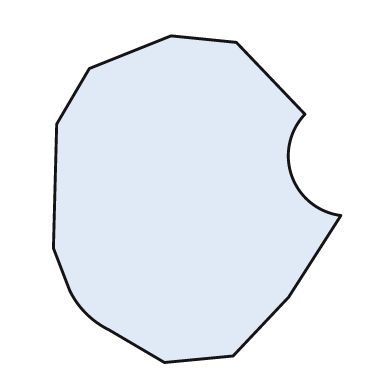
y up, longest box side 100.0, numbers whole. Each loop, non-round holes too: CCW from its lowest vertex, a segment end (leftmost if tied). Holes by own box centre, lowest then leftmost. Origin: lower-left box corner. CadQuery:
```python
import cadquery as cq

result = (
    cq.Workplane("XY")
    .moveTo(34.0, 0.0)
    .lineTo(55.0, 2.0)
    .lineTo(72.0, 20.0)
    .lineTo(88.0, 45.0)
    .threePointArc((73.0, 57.0), (77.0, 76.0))
    .lineTo(56.0, 98.0)
    .lineTo(36.0, 100.0)
    .lineTo(11.0, 90.0)
    .lineTo(1.0, 73.0)
    .lineTo(0.0, 35.0)
    .lineTo(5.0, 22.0)
    .threePointArc((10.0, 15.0), (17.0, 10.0))
    .close()
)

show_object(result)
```